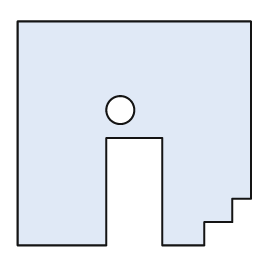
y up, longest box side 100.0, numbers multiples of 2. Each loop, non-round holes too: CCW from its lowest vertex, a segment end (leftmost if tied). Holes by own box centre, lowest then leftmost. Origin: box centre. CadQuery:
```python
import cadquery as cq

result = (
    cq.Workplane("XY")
    .moveTo(-50.0, -48.0)
    .lineTo(-12.0, -48.0)
    .lineTo(-12.0, -2.0)
    .lineTo(12.0, -2.0)
    .lineTo(12.0, -48.0)
    .lineTo(30.0, -48.0)
    .lineTo(30.0, -38.0)
    .lineTo(42.0, -38.0)
    .lineTo(42.0, -28.0)
    .lineTo(50.0, -28.0)
    .lineTo(50.0, 48.0)
    .lineTo(-50.0, 48.0)
    .close()
    .moveTo(-6.0, 10.0)
    .circle(6.0)
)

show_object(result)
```